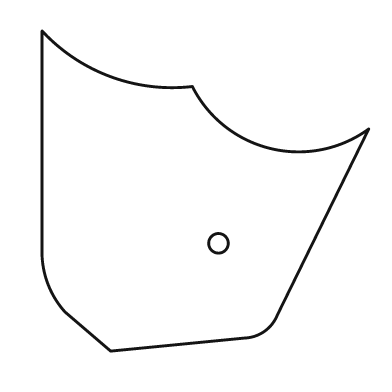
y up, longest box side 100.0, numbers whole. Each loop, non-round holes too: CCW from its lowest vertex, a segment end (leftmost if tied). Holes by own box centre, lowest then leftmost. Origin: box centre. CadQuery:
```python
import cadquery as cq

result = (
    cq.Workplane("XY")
    .moveTo(-29.0, -49.0)
    .lineTo(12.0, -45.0)
    .threePointArc((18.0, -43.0), (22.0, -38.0))
    .lineTo(50.0, 19.0)
    .threePointArc((20.0, 13.0), (-4.0, 32.0))
    .threePointArc((-29.0, 35.0), (-50.0, 49.0))
    .lineTo(-50.0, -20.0)
    .threePointArc((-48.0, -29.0), (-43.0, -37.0))
    .close()
    .moveTo(4.0, -16.0)
    .circle(3.0)
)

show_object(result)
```